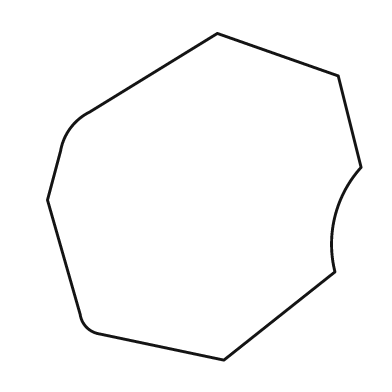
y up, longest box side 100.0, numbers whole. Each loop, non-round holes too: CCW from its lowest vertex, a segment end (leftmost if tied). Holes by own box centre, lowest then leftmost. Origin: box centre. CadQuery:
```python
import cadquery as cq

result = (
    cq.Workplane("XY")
    .moveTo(6.0, -50.0)
    .lineTo(40.0, -23.0)
    .threePointArc((40.0, -6.0), (48.0, 9.0))
    .lineTo(41.0, 37.0)
    .lineTo(4.0, 50.0)
    .lineTo(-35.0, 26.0)
    .threePointArc((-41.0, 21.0), (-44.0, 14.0))
    .lineTo(-48.0, -1.0)
    .lineTo(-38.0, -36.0)
    .threePointArc((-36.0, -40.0), (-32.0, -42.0))
    .close()
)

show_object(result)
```